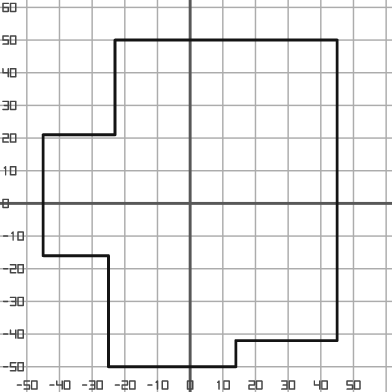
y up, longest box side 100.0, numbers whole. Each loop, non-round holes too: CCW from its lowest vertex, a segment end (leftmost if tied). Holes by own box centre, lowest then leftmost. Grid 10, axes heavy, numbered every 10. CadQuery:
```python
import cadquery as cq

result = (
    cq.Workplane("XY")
    .moveTo(-25.0, -50.0)
    .lineTo(14.0, -50.0)
    .lineTo(14.0, -42.0)
    .lineTo(45.0, -42.0)
    .lineTo(45.0, 50.0)
    .lineTo(-23.0, 50.0)
    .lineTo(-23.0, 21.0)
    .lineTo(-45.0, 21.0)
    .lineTo(-45.0, -16.0)
    .lineTo(-25.0, -16.0)
    .close()
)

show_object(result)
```